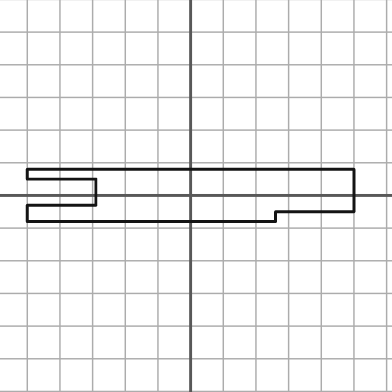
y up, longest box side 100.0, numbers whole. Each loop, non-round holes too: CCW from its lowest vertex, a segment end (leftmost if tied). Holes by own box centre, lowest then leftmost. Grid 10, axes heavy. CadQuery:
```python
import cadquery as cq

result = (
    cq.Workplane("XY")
    .moveTo(-50.0, -8.0)
    .lineTo(26.0, -8.0)
    .lineTo(26.0, -5.0)
    .lineTo(50.0, -5.0)
    .lineTo(50.0, 8.0)
    .lineTo(-50.0, 8.0)
    .lineTo(-50.0, 5.0)
    .lineTo(-29.0, 5.0)
    .lineTo(-29.0, -3.0)
    .lineTo(-50.0, -3.0)
    .close()
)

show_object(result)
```